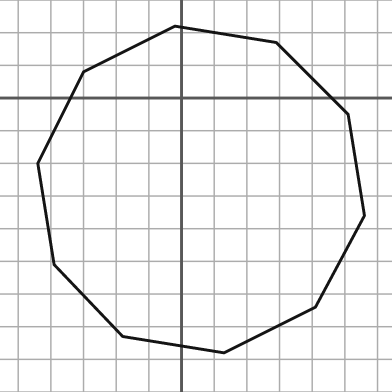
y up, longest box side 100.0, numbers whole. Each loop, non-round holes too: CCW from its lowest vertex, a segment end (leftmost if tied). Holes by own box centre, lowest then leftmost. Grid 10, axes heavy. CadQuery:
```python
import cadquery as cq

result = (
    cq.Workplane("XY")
    .moveTo(13.0, -78.0)
    .lineTo(41.0, -64.0)
    .lineTo(56.0, -36.0)
    .lineTo(51.0, -5.0)
    .lineTo(29.0, 17.0)
    .lineTo(-2.0, 22.0)
    .lineTo(-30.0, 8.0)
    .lineTo(-44.0, -20.0)
    .lineTo(-39.0, -51.0)
    .lineTo(-18.0, -73.0)
    .close()
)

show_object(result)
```